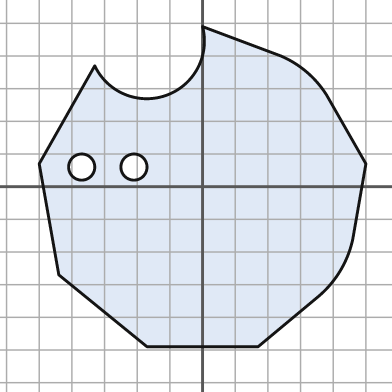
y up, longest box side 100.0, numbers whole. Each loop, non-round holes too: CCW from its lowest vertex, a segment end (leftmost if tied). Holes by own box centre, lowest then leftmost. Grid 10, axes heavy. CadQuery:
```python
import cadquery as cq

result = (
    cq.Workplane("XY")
    .moveTo(-17.0, -49.0)
    .lineTo(17.0, -49.0)
    .lineTo(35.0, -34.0)
    .threePointArc((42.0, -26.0), (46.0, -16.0))
    .lineTo(50.0, 7.0)
    .lineTo(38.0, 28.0)
    .threePointArc((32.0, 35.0), (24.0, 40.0))
    .lineTo(0.0, 49.0)
    .threePointArc((-11.0, 28.0), (-33.0, 37.0))
    .lineTo(-50.0, 7.0)
    .lineTo(-44.0, -27.0)
    .close()
    .moveTo(-37.0, 6.0)
    .circle(4.0)
    .moveTo(-21.0, 6.0)
    .circle(4.0)
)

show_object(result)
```